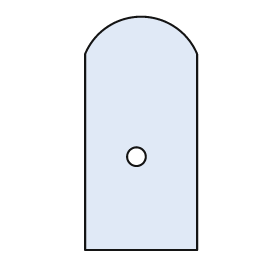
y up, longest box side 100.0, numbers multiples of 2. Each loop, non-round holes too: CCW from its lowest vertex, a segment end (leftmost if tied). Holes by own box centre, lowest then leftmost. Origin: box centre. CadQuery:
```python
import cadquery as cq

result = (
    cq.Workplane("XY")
    .moveTo(-24.0, -50.0)
    .lineTo(24.0, -50.0)
    .lineTo(24.0, 34.0)
    .threePointArc((0.0, 50.0), (-24.0, 34.0))
    .close()
    .moveTo(-2.0, -10.0)
    .circle(4.0)
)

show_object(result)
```